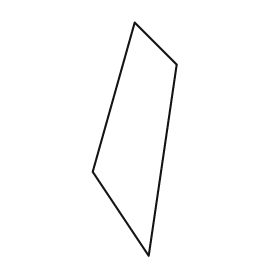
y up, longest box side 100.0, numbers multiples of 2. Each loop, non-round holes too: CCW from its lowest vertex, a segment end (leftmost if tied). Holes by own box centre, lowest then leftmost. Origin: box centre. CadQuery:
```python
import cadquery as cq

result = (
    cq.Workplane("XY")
    .moveTo(6.0, -50.0)
    .lineTo(18.0, 32.0)
    .lineTo(0.0, 50.0)
    .lineTo(-18.0, -14.0)
    .close()
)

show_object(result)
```